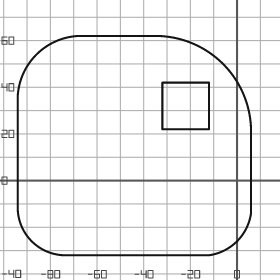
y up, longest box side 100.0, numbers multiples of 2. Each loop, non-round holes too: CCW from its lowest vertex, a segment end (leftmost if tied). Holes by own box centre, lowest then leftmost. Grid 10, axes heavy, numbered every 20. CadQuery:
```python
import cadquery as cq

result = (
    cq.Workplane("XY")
    .moveTo(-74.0, -32.0)
    .lineTo(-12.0, -32.0)
    .threePointArc((0.0, -26.0), (6.0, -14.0))
    .lineTo(6.0, 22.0)
    .threePointArc((-6.0, 50.0), (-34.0, 62.0))
    .lineTo(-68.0, 62.0)
    .threePointArc((-86.0, 54.0), (-94.0, 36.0))
    .lineTo(-94.0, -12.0)
    .threePointArc((-88.0, -26.0), (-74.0, -32.0))
    .close()
    .moveTo(-32.0, 22.0)
    .lineTo(-12.0, 22.0)
    .lineTo(-12.0, 42.0)
    .lineTo(-32.0, 42.0)
    .close()
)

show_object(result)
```